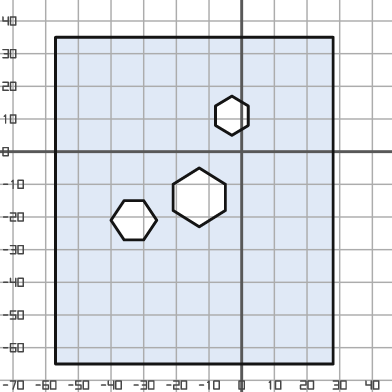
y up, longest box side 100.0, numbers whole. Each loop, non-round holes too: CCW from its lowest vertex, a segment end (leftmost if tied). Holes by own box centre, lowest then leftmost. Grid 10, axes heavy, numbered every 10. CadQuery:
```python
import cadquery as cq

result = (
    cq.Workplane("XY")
    .moveTo(-57.0, -65.0)
    .lineTo(28.0, -65.0)
    .lineTo(28.0, 35.0)
    .lineTo(-57.0, 35.0)
    .close()
    .moveTo(-36.0, -27.0)
    .lineTo(-30.0, -27.0)
    .lineTo(-26.0, -21.0)
    .lineTo(-30.0, -15.0)
    .lineTo(-36.0, -15.0)
    .lineTo(-40.0, -21.0)
    .close()
    .moveTo(-13.0, -23.0)
    .lineTo(-5.0, -18.0)
    .lineTo(-5.0, -10.0)
    .lineTo(-13.0, -5.0)
    .lineTo(-21.0, -10.0)
    .lineTo(-21.0, -18.0)
    .close()
    .moveTo(-3.0, 5.0)
    .lineTo(2.0, 8.0)
    .lineTo(2.0, 14.0)
    .lineTo(-3.0, 17.0)
    .lineTo(-8.0, 14.0)
    .lineTo(-8.0, 8.0)
    .close()
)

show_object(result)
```